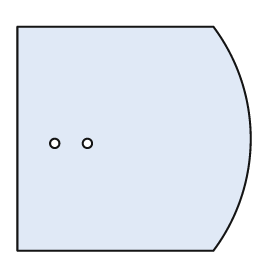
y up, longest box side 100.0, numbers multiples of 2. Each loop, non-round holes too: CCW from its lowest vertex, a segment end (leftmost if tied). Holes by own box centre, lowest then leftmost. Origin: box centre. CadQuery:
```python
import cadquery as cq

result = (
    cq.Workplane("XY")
    .moveTo(-50.0, -48.0)
    .lineTo(34.0, -48.0)
    .threePointArc((50.0, 0.0), (34.0, 48.0))
    .lineTo(-50.0, 48.0)
    .close()
    .moveTo(-34.0, -2.0)
    .circle(2.0)
    .moveTo(-20.0, -2.0)
    .circle(2.0)
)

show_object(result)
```